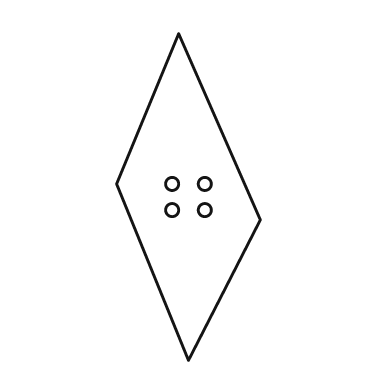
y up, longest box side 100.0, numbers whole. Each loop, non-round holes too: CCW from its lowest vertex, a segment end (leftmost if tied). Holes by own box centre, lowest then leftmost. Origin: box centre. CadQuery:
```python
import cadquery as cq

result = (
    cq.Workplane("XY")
    .moveTo(0.0, -50.0)
    .lineTo(22.0, -7.0)
    .lineTo(-3.0, 50.0)
    .lineTo(-22.0, 4.0)
    .close()
    .moveTo(-5.0, -4.0)
    .circle(2.0)
    .moveTo(5.0, -4.0)
    .circle(2.0)
    .moveTo(-5.0, 4.0)
    .circle(2.0)
    .moveTo(5.0, 4.0)
    .circle(2.0)
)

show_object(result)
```